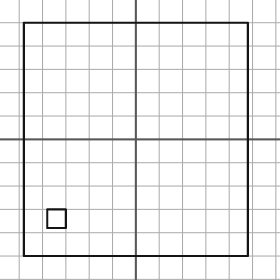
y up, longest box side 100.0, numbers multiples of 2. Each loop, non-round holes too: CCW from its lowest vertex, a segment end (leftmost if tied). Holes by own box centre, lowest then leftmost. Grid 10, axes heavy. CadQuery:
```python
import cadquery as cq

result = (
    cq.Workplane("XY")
    .moveTo(-48.0, -50.0)
    .lineTo(48.0, -50.0)
    .lineTo(48.0, 50.0)
    .lineTo(-48.0, 50.0)
    .close()
    .moveTo(-38.0, -38.0)
    .lineTo(-30.0, -38.0)
    .lineTo(-30.0, -30.0)
    .lineTo(-38.0, -30.0)
    .close()
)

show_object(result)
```